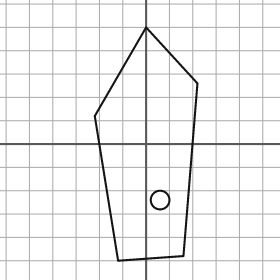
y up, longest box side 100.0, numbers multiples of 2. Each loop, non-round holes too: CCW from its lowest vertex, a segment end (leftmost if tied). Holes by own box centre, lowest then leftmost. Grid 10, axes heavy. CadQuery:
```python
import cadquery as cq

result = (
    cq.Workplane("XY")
    .moveTo(-12.0, -50.0)
    .lineTo(16.0, -48.0)
    .lineTo(22.0, 26.0)
    .lineTo(0.0, 50.0)
    .lineTo(-22.0, 12.0)
    .close()
    .moveTo(6.0, -24.0)
    .circle(4.0)
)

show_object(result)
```